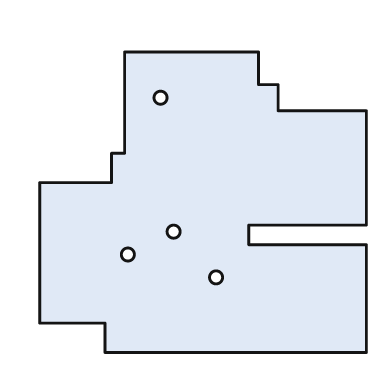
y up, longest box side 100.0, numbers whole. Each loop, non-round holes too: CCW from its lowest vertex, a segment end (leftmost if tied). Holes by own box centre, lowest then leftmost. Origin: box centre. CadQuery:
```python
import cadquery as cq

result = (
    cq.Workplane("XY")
    .moveTo(-30.0, -46.0)
    .lineTo(50.0, -46.0)
    .lineTo(50.0, -13.0)
    .lineTo(14.0, -13.0)
    .lineTo(14.0, -7.0)
    .lineTo(50.0, -7.0)
    .lineTo(50.0, 28.0)
    .lineTo(23.0, 28.0)
    .lineTo(23.0, 36.0)
    .lineTo(17.0, 36.0)
    .lineTo(17.0, 46.0)
    .lineTo(-24.0, 46.0)
    .lineTo(-24.0, 15.0)
    .lineTo(-28.0, 15.0)
    .lineTo(-28.0, 6.0)
    .lineTo(-50.0, 6.0)
    .lineTo(-50.0, -37.0)
    .lineTo(-30.0, -37.0)
    .close()
    .moveTo(4.0, -23.0)
    .circle(2.0)
    .moveTo(-23.0, -16.0)
    .circle(2.0)
    .moveTo(-9.0, -9.0)
    .circle(2.0)
    .moveTo(-13.0, 32.0)
    .circle(2.0)
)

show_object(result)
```